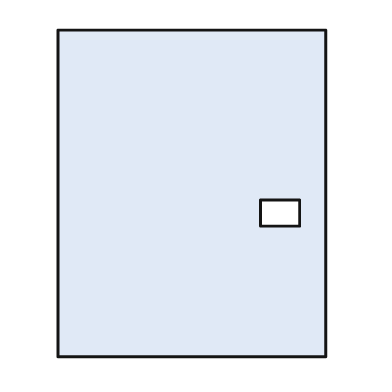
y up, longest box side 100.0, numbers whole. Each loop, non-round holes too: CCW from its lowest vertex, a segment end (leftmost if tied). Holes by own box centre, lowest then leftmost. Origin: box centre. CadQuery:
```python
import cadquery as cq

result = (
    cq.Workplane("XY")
    .moveTo(-41.0, -50.0)
    .lineTo(41.0, -50.0)
    .lineTo(41.0, 50.0)
    .lineTo(-41.0, 50.0)
    .close()
    .moveTo(21.0, -10.0)
    .lineTo(33.0, -10.0)
    .lineTo(33.0, -2.0)
    .lineTo(21.0, -2.0)
    .close()
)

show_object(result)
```